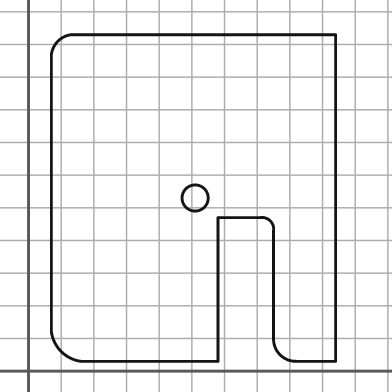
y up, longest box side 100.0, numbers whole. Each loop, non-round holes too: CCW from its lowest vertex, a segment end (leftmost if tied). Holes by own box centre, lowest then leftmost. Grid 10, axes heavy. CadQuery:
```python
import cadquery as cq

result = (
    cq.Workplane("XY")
    .moveTo(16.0, 3.0)
    .lineTo(58.0, 3.0)
    .lineTo(58.0, 47.0)
    .lineTo(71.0, 47.0)
    .threePointArc((74.0, 46.0), (75.0, 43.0))
    .lineTo(75.0, 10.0)
    .threePointArc((77.0, 5.0), (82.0, 3.0))
    .lineTo(94.0, 3.0)
    .lineTo(94.0, 103.0)
    .lineTo(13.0, 103.0)
    .threePointArc((9.0, 101.0), (7.0, 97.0))
    .lineTo(7.0, 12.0)
    .threePointArc((10.0, 6.0), (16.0, 3.0))
    .close()
    .moveTo(51.0, 53.0)
    .circle(4.0)
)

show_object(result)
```